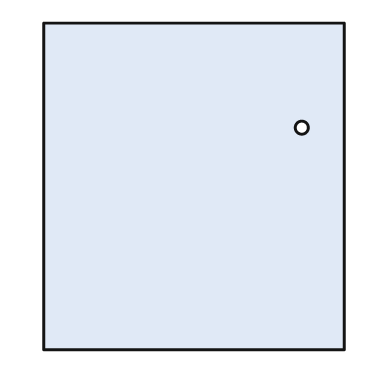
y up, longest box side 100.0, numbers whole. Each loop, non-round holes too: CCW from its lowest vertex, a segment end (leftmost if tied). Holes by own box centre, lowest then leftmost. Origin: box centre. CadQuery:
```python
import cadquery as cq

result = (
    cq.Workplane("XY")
    .moveTo(-46.0, -50.0)
    .lineTo(46.0, -50.0)
    .lineTo(46.0, 50.0)
    .lineTo(-46.0, 50.0)
    .close()
    .moveTo(33.0, 18.0)
    .circle(2.0)
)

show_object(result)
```